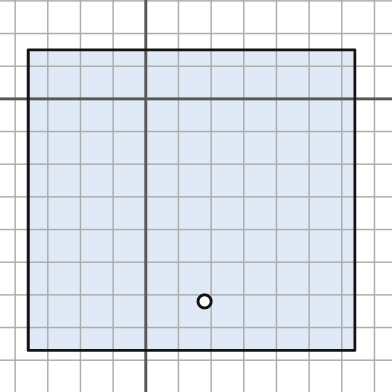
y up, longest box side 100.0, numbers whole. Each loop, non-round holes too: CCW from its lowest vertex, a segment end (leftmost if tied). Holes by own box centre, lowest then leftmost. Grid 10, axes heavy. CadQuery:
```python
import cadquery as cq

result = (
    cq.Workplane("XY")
    .moveTo(-36.0, -77.0)
    .lineTo(64.0, -77.0)
    .lineTo(64.0, 15.0)
    .lineTo(-36.0, 15.0)
    .close()
    .moveTo(18.0, -62.0)
    .circle(2.0)
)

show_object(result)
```